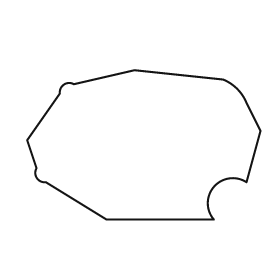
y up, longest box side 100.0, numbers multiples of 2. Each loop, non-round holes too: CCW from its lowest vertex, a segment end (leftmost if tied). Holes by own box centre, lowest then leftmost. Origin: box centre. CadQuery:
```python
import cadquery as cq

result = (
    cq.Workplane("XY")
    .moveTo(-16.0, -32.0)
    .lineTo(30.0, -32.0)
    .threePointArc((30.0, -18.0), (44.0, -16.0))
    .lineTo(50.0, 6.0)
    .lineTo(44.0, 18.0)
    .threePointArc((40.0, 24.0), (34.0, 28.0))
    .lineTo(-4.0, 32.0)
    .lineTo(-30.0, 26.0)
    .threePointArc((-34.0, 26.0), (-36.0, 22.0))
    .lineTo(-50.0, 2.0)
    .lineTo(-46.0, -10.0)
    .threePointArc((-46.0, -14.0), (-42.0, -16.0))
    .close()
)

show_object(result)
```